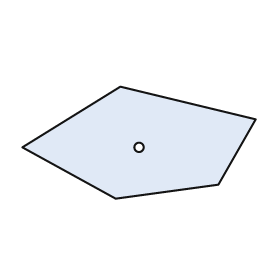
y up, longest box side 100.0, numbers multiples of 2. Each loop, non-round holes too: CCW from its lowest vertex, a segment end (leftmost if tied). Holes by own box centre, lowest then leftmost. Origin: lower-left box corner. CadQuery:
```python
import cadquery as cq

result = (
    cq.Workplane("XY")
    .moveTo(40.0, 0.0)
    .lineTo(84.0, 6.0)
    .lineTo(100.0, 34.0)
    .lineTo(42.0, 48.0)
    .lineTo(0.0, 22.0)
    .close()
    .moveTo(50.0, 22.0)
    .circle(2.0)
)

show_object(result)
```